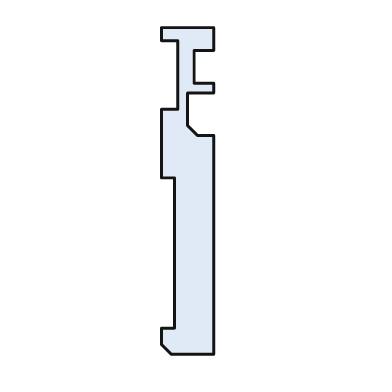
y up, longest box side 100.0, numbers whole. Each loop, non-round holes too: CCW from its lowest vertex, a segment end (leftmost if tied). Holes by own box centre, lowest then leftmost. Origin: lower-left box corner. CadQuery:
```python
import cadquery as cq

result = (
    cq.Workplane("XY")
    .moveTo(3.0, 0.0)
    .lineTo(16.0, 0.0)
    .lineTo(16.0, 67.0)
    .lineTo(11.0, 67.0)
    .lineTo(8.0, 70.0)
    .lineTo(8.0, 80.0)
    .lineTo(16.0, 80.0)
    .lineTo(16.0, 83.0)
    .lineTo(10.0, 83.0)
    .lineTo(10.0, 93.0)
    .lineTo(16.0, 93.0)
    .lineTo(16.0, 100.0)
    .lineTo(0.0, 100.0)
    .lineTo(0.0, 96.0)
    .lineTo(5.0, 96.0)
    .lineTo(5.0, 75.0)
    .lineTo(0.0, 75.0)
    .lineTo(0.0, 54.0)
    .lineTo(4.0, 54.0)
    .lineTo(4.0, 8.0)
    .lineTo(0.0, 8.0)
    .lineTo(0.0, 3.0)
    .close()
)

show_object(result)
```